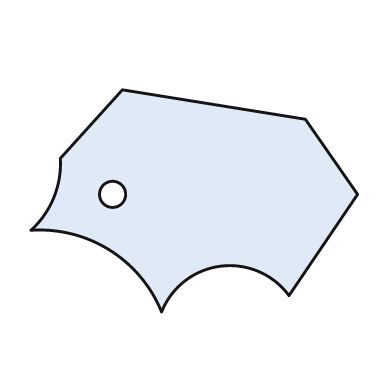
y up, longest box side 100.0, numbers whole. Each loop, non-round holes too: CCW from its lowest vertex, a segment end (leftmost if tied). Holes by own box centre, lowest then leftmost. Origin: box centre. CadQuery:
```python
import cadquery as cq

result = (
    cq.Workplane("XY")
    .moveTo(-10.0, -34.0)
    .threePointArc((8.0, -20.0), (29.0, -29.0))
    .lineTo(50.0, 2.0)
    .lineTo(34.0, 25.0)
    .lineTo(-22.0, 34.0)
    .lineTo(-41.0, 13.0)
    .threePointArc((-43.0, 1.0), (-50.0, -9.0))
    .threePointArc((-26.0, -15.0), (-10.0, -34.0))
    .close()
    .moveTo(-25.0, 2.0)
    .circle(4.0)
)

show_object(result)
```